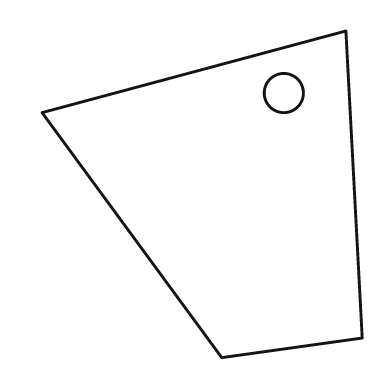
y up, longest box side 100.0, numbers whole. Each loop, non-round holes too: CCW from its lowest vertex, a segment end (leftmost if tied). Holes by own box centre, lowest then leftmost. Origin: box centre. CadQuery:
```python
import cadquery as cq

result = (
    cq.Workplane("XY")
    .moveTo(6.0, -50.0)
    .lineTo(49.0, -44.0)
    .lineTo(44.0, 50.0)
    .lineTo(-49.0, 25.0)
    .close()
    .moveTo(25.0, 31.0)
    .circle(6.0)
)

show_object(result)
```